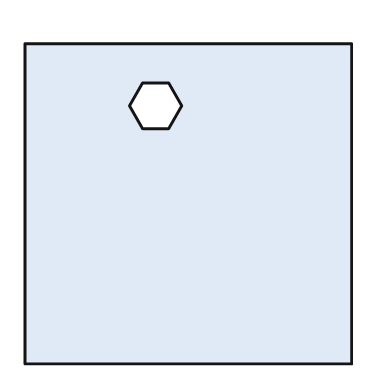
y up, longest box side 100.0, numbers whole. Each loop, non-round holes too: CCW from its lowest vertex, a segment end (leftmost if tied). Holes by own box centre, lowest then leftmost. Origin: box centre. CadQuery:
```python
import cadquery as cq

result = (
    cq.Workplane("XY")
    .moveTo(-50.0, -49.0)
    .lineTo(50.0, -49.0)
    .lineTo(50.0, 49.0)
    .lineTo(-50.0, 49.0)
    .close()
    .moveTo(-14.0, 23.0)
    .lineTo(-6.0, 23.0)
    .lineTo(-2.0, 30.0)
    .lineTo(-6.0, 37.0)
    .lineTo(-14.0, 37.0)
    .lineTo(-18.0, 30.0)
    .close()
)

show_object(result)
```